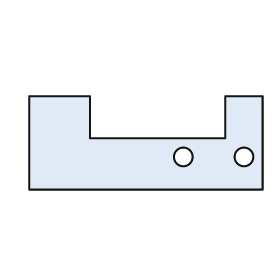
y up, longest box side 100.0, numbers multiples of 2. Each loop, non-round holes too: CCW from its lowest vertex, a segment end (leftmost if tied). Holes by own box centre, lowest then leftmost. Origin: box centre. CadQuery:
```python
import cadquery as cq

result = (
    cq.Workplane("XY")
    .moveTo(-50.0, -20.0)
    .lineTo(50.0, -20.0)
    .lineTo(50.0, 20.0)
    .lineTo(34.0, 20.0)
    .lineTo(34.0, 2.0)
    .lineTo(-24.0, 2.0)
    .lineTo(-24.0, 20.0)
    .lineTo(-50.0, 20.0)
    .close()
    .moveTo(16.0, -6.0)
    .circle(4.0)
    .moveTo(42.0, -6.0)
    .circle(4.0)
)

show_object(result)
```